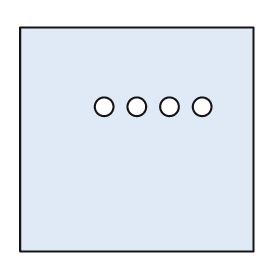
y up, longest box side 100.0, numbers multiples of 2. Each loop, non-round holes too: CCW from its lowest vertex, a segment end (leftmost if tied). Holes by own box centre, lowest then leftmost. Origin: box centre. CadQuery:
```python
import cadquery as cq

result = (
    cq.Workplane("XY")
    .moveTo(-50.0, -48.0)
    .lineTo(50.0, -48.0)
    .lineTo(50.0, 48.0)
    .lineTo(-50.0, 48.0)
    .close()
    .moveTo(-14.0, 14.0)
    .circle(4.0)
    .moveTo(0.0, 14.0)
    .circle(4.0)
    .moveTo(14.0, 14.0)
    .circle(4.0)
    .moveTo(28.0, 14.0)
    .circle(4.0)
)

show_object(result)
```